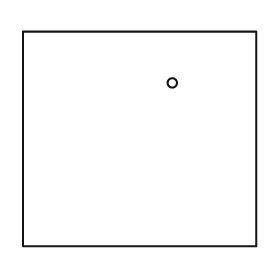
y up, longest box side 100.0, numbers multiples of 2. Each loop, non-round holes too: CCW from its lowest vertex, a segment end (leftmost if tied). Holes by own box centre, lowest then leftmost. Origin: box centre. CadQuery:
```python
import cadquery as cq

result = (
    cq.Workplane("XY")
    .moveTo(-50.0, -46.0)
    .lineTo(50.0, -46.0)
    .lineTo(50.0, 46.0)
    .lineTo(-50.0, 46.0)
    .close()
    .moveTo(14.0, 24.0)
    .circle(2.0)
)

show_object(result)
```